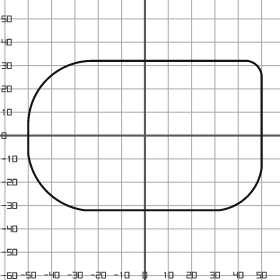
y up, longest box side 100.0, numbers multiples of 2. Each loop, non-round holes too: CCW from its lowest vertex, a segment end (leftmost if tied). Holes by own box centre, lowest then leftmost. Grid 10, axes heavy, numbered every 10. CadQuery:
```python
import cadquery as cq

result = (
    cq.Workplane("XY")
    .moveTo(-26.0, -32.0)
    .lineTo(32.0, -32.0)
    .threePointArc((44.0, -26.0), (50.0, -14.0))
    .lineTo(50.0, 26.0)
    .threePointArc((48.0, 30.0), (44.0, 32.0))
    .lineTo(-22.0, 32.0)
    .threePointArc((-42.0, 24.0), (-50.0, 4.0))
    .lineTo(-50.0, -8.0)
    .threePointArc((-42.0, -24.0), (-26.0, -32.0))
    .close()
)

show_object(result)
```